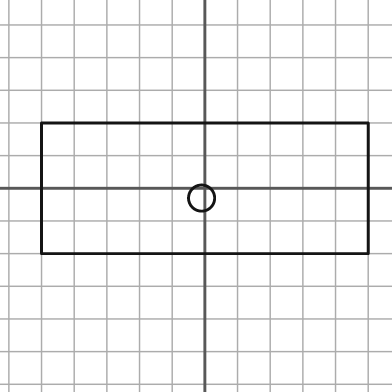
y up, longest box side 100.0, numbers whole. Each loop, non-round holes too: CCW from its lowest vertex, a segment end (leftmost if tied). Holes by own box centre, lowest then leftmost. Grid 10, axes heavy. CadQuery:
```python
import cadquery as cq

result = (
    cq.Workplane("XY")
    .moveTo(-50.0, -20.0)
    .lineTo(50.0, -20.0)
    .lineTo(50.0, 20.0)
    .lineTo(-50.0, 20.0)
    .close()
    .moveTo(-1.0, -3.0)
    .circle(4.0)
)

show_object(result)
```